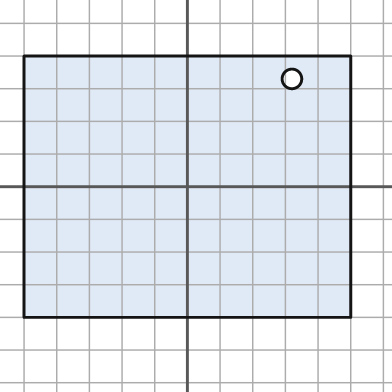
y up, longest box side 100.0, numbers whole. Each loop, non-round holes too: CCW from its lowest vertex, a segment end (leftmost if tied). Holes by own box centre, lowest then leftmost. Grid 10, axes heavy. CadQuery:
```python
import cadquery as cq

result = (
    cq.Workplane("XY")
    .moveTo(-50.0, -40.0)
    .lineTo(50.0, -40.0)
    .lineTo(50.0, 40.0)
    .lineTo(-50.0, 40.0)
    .close()
    .moveTo(32.0, 33.0)
    .circle(3.0)
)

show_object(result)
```